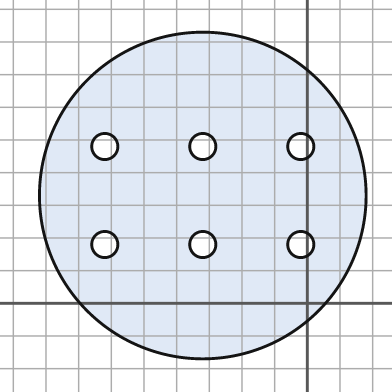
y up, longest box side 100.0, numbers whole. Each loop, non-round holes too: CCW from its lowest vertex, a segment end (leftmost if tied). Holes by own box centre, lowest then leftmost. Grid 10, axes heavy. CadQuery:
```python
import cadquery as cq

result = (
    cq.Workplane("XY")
    .moveTo(-32.0, 33.0)
    .circle(50.0)
    .moveTo(-62.0, 18.0)
    .circle(4.0)
    .moveTo(-32.0, 18.0)
    .circle(4.0)
    .moveTo(-2.0, 18.0)
    .circle(4.0)
    .moveTo(-62.0, 48.0)
    .circle(4.0)
    .moveTo(-32.0, 48.0)
    .circle(4.0)
    .moveTo(-2.0, 48.0)
    .circle(4.0)
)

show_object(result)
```